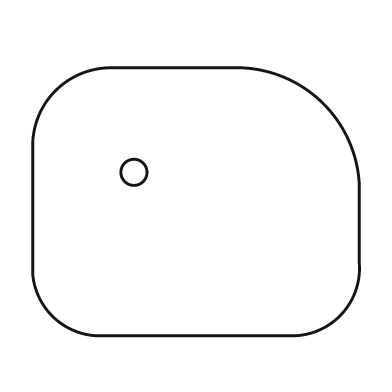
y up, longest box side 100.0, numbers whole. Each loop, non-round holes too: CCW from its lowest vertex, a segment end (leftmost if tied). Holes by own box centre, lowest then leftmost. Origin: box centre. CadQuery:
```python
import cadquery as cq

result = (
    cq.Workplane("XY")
    .moveTo(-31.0, -41.0)
    .lineTo(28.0, -41.0)
    .threePointArc((44.0, -35.0), (50.0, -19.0))
    .lineTo(50.0, 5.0)
    .threePointArc((39.0, 30.0), (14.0, 41.0))
    .lineTo(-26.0, 41.0)
    .threePointArc((-43.0, 34.0), (-50.0, 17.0))
    .lineTo(-50.0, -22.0)
    .threePointArc((-44.0, -35.0), (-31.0, -41.0))
    .close()
    .moveTo(-19.0, 9.0)
    .circle(4.0)
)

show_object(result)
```